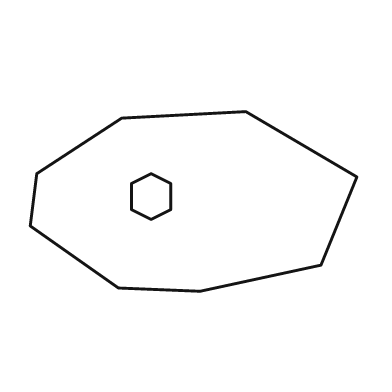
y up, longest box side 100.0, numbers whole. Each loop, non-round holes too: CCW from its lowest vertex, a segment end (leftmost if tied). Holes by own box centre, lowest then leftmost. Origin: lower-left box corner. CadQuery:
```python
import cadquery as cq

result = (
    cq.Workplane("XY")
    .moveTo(52.0, 0.0)
    .lineTo(89.0, 8.0)
    .lineTo(100.0, 35.0)
    .lineTo(66.0, 55.0)
    .lineTo(28.0, 53.0)
    .lineTo(2.0, 36.0)
    .lineTo(0.0, 20.0)
    .lineTo(27.0, 1.0)
    .close()
    .moveTo(37.0, 22.0)
    .lineTo(43.0, 25.0)
    .lineTo(43.0, 33.0)
    .lineTo(37.0, 36.0)
    .lineTo(31.0, 33.0)
    .lineTo(31.0, 25.0)
    .close()
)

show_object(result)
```